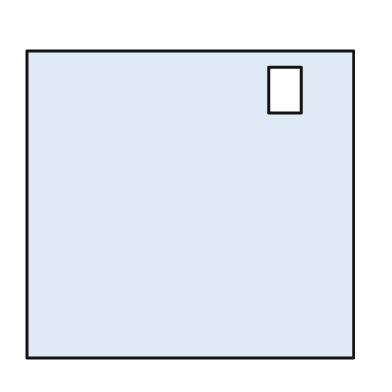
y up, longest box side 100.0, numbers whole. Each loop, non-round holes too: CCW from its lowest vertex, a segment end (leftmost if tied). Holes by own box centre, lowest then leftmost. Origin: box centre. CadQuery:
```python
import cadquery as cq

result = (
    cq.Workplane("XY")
    .moveTo(-50.0, -47.0)
    .lineTo(50.0, -47.0)
    .lineTo(50.0, 47.0)
    .lineTo(-50.0, 47.0)
    .close()
    .moveTo(24.0, 28.0)
    .lineTo(34.0, 28.0)
    .lineTo(34.0, 42.0)
    .lineTo(24.0, 42.0)
    .close()
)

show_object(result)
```